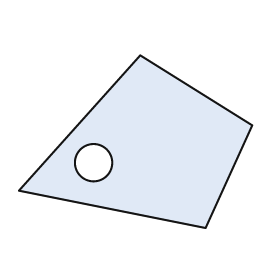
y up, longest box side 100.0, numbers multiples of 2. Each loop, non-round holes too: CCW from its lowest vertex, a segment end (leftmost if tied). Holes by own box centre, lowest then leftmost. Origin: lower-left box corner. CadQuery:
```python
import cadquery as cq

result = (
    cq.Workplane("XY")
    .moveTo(80.0, 0.0)
    .lineTo(100.0, 44.0)
    .lineTo(52.0, 74.0)
    .lineTo(0.0, 16.0)
    .close()
    .moveTo(32.0, 28.0)
    .circle(8.0)
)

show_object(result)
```